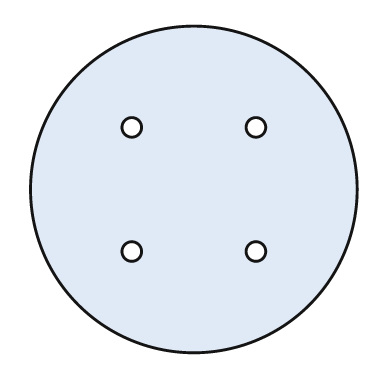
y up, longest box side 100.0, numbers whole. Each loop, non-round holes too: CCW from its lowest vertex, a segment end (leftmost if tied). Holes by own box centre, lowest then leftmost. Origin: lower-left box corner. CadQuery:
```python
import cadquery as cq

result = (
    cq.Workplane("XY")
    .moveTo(50.0, 50.0)
    .circle(50.0)
    .moveTo(31.0, 31.0)
    .circle(3.0)
    .moveTo(69.0, 31.0)
    .circle(3.0)
    .moveTo(31.0, 69.0)
    .circle(3.0)
    .moveTo(69.0, 69.0)
    .circle(3.0)
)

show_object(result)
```